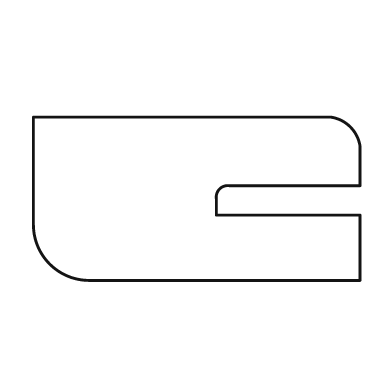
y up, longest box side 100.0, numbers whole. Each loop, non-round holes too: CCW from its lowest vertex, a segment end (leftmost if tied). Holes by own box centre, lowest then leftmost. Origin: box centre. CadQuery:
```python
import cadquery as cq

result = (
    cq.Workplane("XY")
    .moveTo(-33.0, -25.0)
    .lineTo(50.0, -25.0)
    .lineTo(50.0, -5.0)
    .lineTo(6.0, -5.0)
    .lineTo(6.0, 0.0)
    .threePointArc((7.0, 3.0), (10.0, 4.0))
    .lineTo(50.0, 4.0)
    .lineTo(50.0, 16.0)
    .threePointArc((47.0, 22.0), (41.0, 25.0))
    .lineTo(-50.0, 25.0)
    .lineTo(-50.0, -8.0)
    .threePointArc((-45.0, -20.0), (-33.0, -25.0))
    .close()
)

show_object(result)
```